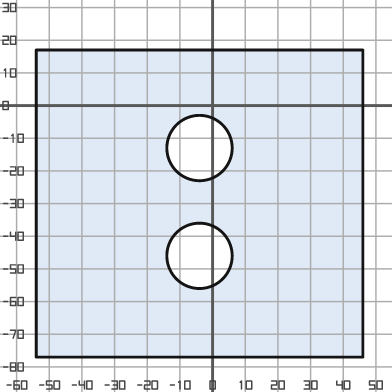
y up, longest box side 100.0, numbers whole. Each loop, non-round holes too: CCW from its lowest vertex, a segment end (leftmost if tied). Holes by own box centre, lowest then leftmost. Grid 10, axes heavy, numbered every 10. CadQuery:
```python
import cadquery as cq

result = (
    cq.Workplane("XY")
    .moveTo(-54.0, -77.0)
    .lineTo(46.0, -77.0)
    .lineTo(46.0, 17.0)
    .lineTo(-54.0, 17.0)
    .close()
    .moveTo(-4.0, -46.0)
    .circle(10.0)
    .moveTo(-4.0, -13.0)
    .circle(10.0)
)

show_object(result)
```